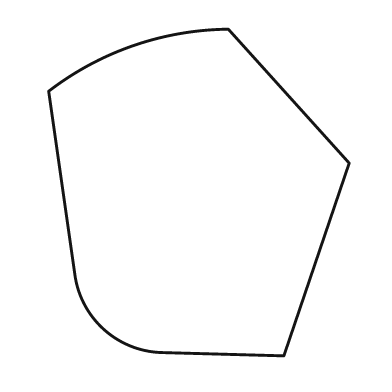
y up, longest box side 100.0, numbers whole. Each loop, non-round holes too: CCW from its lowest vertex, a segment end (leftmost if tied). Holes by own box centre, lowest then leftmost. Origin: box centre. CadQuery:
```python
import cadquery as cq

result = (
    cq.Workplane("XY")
    .moveTo(26.0, -50.0)
    .lineTo(46.0, 9.0)
    .lineTo(9.0, 50.0)
    .threePointArc((-20.0, 45.0), (-46.0, 31.0))
    .lineTo(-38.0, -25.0)
    .threePointArc((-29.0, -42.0), (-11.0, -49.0))
    .close()
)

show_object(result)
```